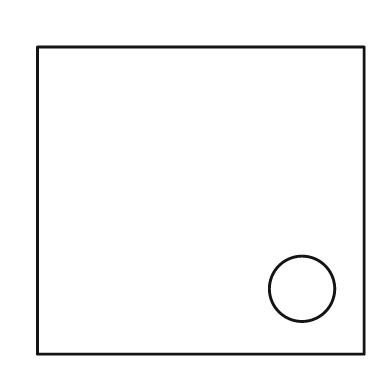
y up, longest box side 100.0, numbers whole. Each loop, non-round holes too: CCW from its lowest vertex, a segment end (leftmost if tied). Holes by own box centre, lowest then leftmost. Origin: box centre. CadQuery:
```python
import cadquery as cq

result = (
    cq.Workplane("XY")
    .moveTo(-50.0, -47.0)
    .lineTo(50.0, -47.0)
    .lineTo(50.0, 47.0)
    .lineTo(-50.0, 47.0)
    .close()
    .moveTo(31.0, -27.0)
    .circle(10.0)
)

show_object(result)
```